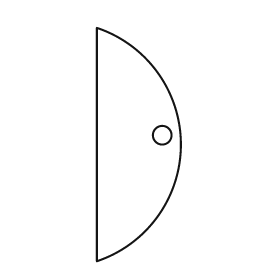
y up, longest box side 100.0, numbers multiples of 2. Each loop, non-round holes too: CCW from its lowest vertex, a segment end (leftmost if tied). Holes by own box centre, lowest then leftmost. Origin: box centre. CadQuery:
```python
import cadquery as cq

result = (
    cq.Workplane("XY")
    .moveTo(-18.0, -50.0)
    .threePointArc((18.0, 0.0), (-18.0, 50.0))
    .close()
    .moveTo(10.0, 4.0)
    .circle(4.0)
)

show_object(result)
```